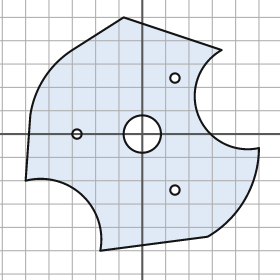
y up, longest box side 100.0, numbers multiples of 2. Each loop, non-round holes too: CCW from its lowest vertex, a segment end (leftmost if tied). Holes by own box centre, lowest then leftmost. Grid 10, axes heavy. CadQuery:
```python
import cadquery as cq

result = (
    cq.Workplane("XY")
    .moveTo(-18.0, -50.0)
    .lineTo(28.0, -44.0)
    .threePointArc((44.0, -28.0), (50.0, -6.0))
    .threePointArc((24.0, 8.0), (34.0, 36.0))
    .lineTo(-8.0, 50.0)
    .lineTo(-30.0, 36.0)
    .threePointArc((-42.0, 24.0), (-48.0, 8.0))
    .lineTo(-50.0, -20.0)
    .threePointArc((-26.0, -26.0), (-18.0, -50.0))
    .close()
    .moveTo(14.0, -24.0)
    .circle(2.0)
    .moveTo(-28.0, 0.0)
    .circle(2.0)
    .moveTo(0.0, 0.0)
    .circle(8.0)
    .moveTo(14.0, 24.0)
    .circle(2.0)
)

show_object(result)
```